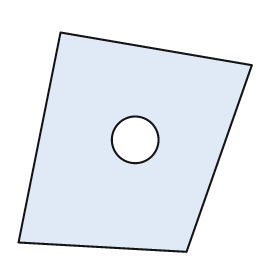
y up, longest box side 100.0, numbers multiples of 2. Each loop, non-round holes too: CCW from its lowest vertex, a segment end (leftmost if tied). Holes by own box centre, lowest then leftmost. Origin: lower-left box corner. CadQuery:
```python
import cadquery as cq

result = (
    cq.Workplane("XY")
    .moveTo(72.0, 0.0)
    .lineTo(100.0, 80.0)
    .lineTo(18.0, 94.0)
    .lineTo(0.0, 4.0)
    .close()
    .moveTo(50.0, 48.0)
    .circle(10.0)
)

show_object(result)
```